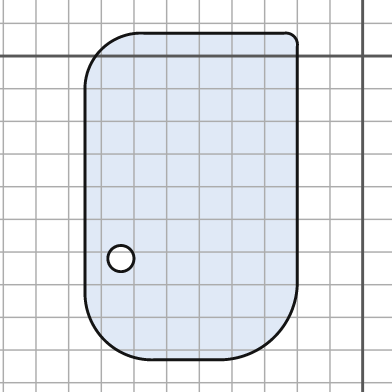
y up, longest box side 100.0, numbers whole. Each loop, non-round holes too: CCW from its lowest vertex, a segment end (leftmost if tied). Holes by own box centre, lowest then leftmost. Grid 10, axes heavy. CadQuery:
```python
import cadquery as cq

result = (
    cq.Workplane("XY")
    .moveTo(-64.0, -93.0)
    .lineTo(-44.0, -93.0)
    .threePointArc((-27.0, -86.0), (-20.0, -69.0))
    .lineTo(-20.0, 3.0)
    .threePointArc((-21.0, 6.0), (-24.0, 7.0))
    .lineTo(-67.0, 7.0)
    .threePointArc((-80.0, 2.0), (-85.0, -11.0))
    .lineTo(-85.0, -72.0)
    .threePointArc((-79.0, -87.0), (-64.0, -93.0))
    .close()
    .moveTo(-74.0, -62.0)
    .circle(4.0)
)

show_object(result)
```